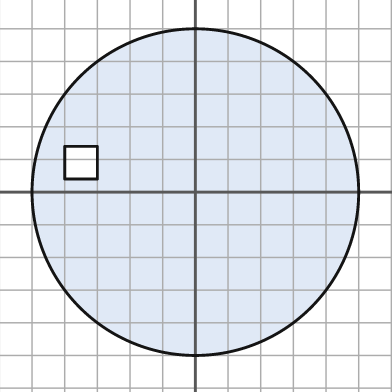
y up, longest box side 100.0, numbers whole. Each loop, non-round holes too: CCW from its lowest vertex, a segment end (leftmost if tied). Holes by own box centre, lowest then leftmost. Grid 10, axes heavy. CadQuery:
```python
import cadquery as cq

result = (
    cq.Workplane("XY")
    .moveTo(0.0, 0.0)
    .circle(50.0)
    .moveTo(-40.0, 4.0)
    .lineTo(-30.0, 4.0)
    .lineTo(-30.0, 14.0)
    .lineTo(-40.0, 14.0)
    .close()
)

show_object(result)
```